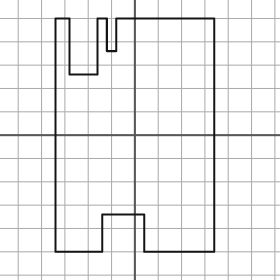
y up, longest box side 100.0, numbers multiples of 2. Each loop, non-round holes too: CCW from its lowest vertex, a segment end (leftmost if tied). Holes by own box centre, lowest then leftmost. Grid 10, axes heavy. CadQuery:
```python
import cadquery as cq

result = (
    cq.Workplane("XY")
    .moveTo(-34.0, -50.0)
    .lineTo(-14.0, -50.0)
    .lineTo(-14.0, -34.0)
    .lineTo(4.0, -34.0)
    .lineTo(4.0, -50.0)
    .lineTo(34.0, -50.0)
    .lineTo(34.0, 50.0)
    .lineTo(-8.0, 50.0)
    .lineTo(-8.0, 36.0)
    .lineTo(-12.0, 36.0)
    .lineTo(-12.0, 50.0)
    .lineTo(-16.0, 50.0)
    .lineTo(-16.0, 26.0)
    .lineTo(-28.0, 26.0)
    .lineTo(-28.0, 50.0)
    .lineTo(-34.0, 50.0)
    .close()
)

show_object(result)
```